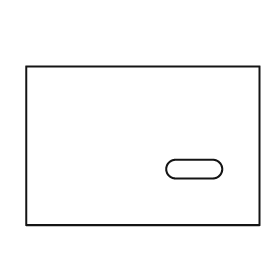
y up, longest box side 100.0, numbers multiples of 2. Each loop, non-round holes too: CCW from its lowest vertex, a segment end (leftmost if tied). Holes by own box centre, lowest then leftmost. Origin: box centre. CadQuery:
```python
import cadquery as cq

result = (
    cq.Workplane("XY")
    .moveTo(-50.0, -34.0)
    .lineTo(50.0, -34.0)
    .lineTo(50.0, 34.0)
    .lineTo(-50.0, 34.0)
    .close()
    .moveTo(14.0, -14.0)
    .lineTo(30.0, -14.0)
    .threePointArc((34.0, -10.0), (30.0, -6.0))
    .lineTo(14.0, -6.0)
    .threePointArc((10.0, -10.0), (14.0, -14.0))
    .close()
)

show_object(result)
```